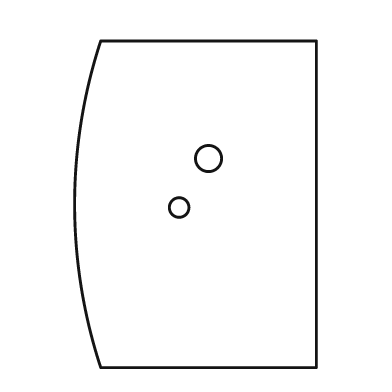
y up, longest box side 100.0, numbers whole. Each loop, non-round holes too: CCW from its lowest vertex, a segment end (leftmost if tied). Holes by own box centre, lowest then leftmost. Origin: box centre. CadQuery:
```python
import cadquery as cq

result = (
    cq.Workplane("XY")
    .moveTo(-29.0, -50.0)
    .lineTo(37.0, -50.0)
    .lineTo(37.0, 50.0)
    .lineTo(-29.0, 50.0)
    .threePointArc((-37.0, 0.0), (-29.0, -50.0))
    .close()
    .moveTo(-5.0, -1.0)
    .circle(3.0)
    .moveTo(4.0, 14.0)
    .circle(4.0)
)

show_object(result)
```